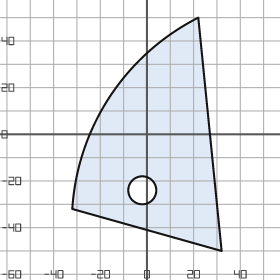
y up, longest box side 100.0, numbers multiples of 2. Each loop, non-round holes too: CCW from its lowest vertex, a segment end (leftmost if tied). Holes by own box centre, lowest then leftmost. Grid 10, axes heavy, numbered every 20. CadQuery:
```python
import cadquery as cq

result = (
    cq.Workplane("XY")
    .moveTo(32.0, -50.0)
    .lineTo(22.0, 50.0)
    .threePointArc((-16.0, 16.0), (-32.0, -32.0))
    .close()
    .moveTo(-2.0, -24.0)
    .circle(6.0)
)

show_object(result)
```